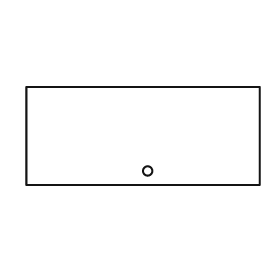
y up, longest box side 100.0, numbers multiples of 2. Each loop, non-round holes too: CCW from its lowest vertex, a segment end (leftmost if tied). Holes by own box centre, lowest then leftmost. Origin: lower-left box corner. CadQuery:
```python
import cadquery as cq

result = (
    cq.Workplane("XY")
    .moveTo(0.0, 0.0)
    .lineTo(100.0, 0.0)
    .lineTo(100.0, 42.0)
    .lineTo(0.0, 42.0)
    .close()
    .moveTo(52.0, 6.0)
    .circle(2.0)
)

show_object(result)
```